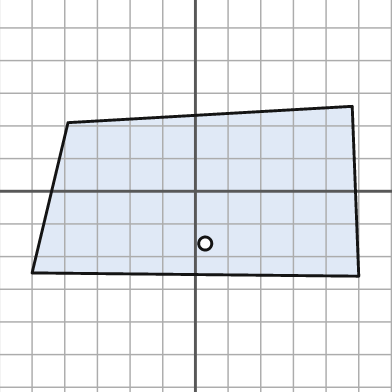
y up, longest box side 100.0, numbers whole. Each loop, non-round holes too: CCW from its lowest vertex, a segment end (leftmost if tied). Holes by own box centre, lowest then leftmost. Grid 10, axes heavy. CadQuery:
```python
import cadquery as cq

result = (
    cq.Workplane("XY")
    .moveTo(50.0, -26.0)
    .lineTo(48.0, 26.0)
    .lineTo(-39.0, 21.0)
    .lineTo(-50.0, -25.0)
    .close()
    .moveTo(3.0, -16.0)
    .circle(2.0)
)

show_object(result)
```